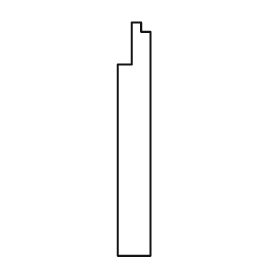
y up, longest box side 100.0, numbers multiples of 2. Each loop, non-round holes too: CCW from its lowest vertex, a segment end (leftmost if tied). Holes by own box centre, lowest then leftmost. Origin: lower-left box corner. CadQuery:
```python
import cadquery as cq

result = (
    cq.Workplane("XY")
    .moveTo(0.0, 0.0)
    .lineTo(14.0, 0.0)
    .lineTo(14.0, 96.0)
    .lineTo(10.0, 96.0)
    .lineTo(10.0, 100.0)
    .lineTo(6.0, 100.0)
    .lineTo(6.0, 82.0)
    .lineTo(0.0, 82.0)
    .close()
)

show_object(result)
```